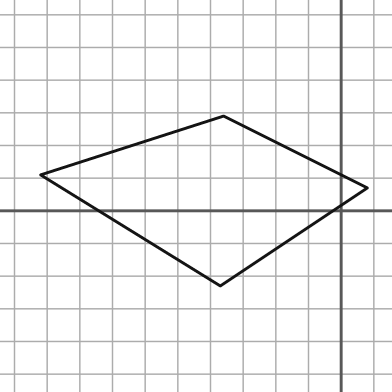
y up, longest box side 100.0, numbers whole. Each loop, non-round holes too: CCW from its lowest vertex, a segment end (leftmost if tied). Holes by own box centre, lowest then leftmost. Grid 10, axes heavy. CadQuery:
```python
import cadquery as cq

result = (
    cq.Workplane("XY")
    .moveTo(-37.0, -23.0)
    .lineTo(8.0, 7.0)
    .lineTo(-36.0, 29.0)
    .lineTo(-92.0, 11.0)
    .close()
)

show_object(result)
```